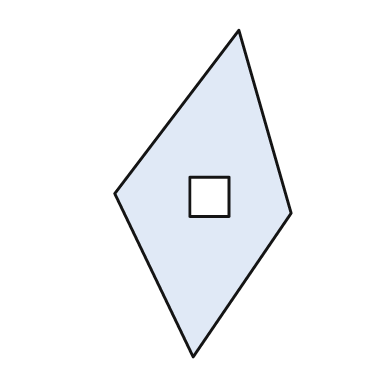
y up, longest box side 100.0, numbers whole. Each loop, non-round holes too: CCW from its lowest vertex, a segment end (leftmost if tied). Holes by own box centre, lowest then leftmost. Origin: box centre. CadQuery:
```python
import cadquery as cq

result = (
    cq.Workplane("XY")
    .moveTo(-3.0, -50.0)
    .lineTo(27.0, -6.0)
    .lineTo(11.0, 50.0)
    .lineTo(-27.0, 0.0)
    .close()
    .moveTo(-4.0, -7.0)
    .lineTo(8.0, -7.0)
    .lineTo(8.0, 5.0)
    .lineTo(-4.0, 5.0)
    .close()
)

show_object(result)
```